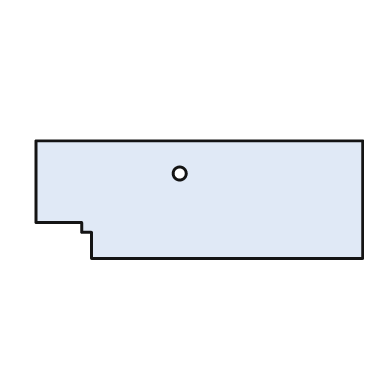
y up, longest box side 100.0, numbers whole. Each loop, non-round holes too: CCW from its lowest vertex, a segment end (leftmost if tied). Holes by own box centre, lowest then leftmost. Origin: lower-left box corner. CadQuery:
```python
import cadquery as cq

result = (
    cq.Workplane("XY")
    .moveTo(17.0, 0.0)
    .lineTo(100.0, 0.0)
    .lineTo(100.0, 36.0)
    .lineTo(0.0, 36.0)
    .lineTo(0.0, 11.0)
    .lineTo(14.0, 11.0)
    .lineTo(14.0, 8.0)
    .lineTo(17.0, 8.0)
    .close()
    .moveTo(44.0, 26.0)
    .circle(2.0)
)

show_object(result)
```